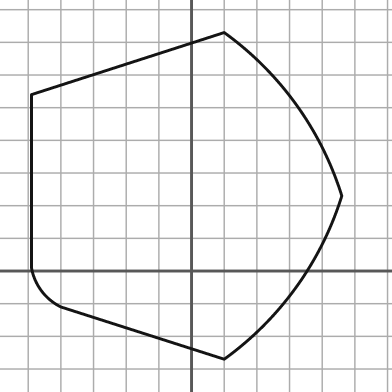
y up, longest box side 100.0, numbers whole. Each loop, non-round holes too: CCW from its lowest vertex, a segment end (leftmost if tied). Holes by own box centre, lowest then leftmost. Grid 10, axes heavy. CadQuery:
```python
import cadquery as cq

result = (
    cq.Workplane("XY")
    .moveTo(10.0, -27.0)
    .threePointArc((32.0, -5.0), (46.0, 23.0))
    .threePointArc((32.0, 51.0), (10.0, 73.0))
    .lineTo(-49.0, 54.0)
    .lineTo(-49.0, 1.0)
    .threePointArc((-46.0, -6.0), (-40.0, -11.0))
    .close()
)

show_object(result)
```